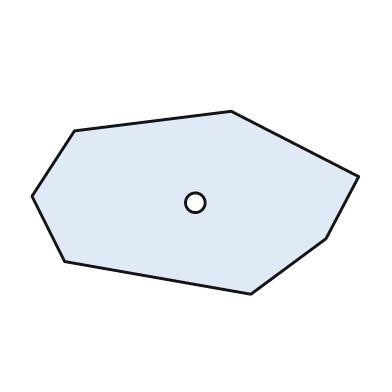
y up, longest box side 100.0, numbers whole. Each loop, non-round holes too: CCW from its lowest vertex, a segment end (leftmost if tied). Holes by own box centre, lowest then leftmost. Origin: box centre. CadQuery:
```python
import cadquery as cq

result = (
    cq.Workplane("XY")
    .moveTo(17.0, -28.0)
    .lineTo(40.0, -11.0)
    .lineTo(50.0, 8.0)
    .lineTo(11.0, 28.0)
    .lineTo(-37.0, 22.0)
    .lineTo(-50.0, 2.0)
    .lineTo(-40.0, -18.0)
    .close()
    .moveTo(0.0, 0.0)
    .circle(3.0)
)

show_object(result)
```